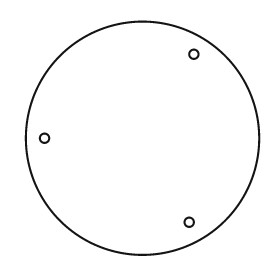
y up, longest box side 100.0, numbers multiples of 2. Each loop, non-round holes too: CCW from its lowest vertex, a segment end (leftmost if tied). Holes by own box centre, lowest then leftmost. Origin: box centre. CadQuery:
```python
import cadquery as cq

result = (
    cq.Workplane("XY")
    .moveTo(0.0, 0.0)
    .circle(50.0)
    .moveTo(20.0, -36.0)
    .circle(2.0)
    .moveTo(-42.0, 0.0)
    .circle(2.0)
    .moveTo(22.0, 36.0)
    .circle(2.0)
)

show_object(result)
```